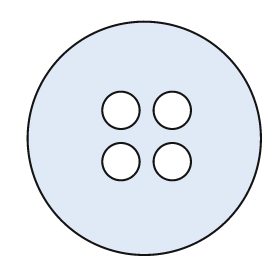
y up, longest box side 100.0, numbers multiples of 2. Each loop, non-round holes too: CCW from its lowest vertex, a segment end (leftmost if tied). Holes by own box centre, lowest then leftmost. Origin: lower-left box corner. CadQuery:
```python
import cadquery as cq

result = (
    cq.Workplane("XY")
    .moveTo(50.0, 50.0)
    .circle(50.0)
    .moveTo(40.0, 40.0)
    .circle(8.0)
    .moveTo(62.0, 40.0)
    .circle(8.0)
    .moveTo(40.0, 62.0)
    .circle(8.0)
    .moveTo(62.0, 62.0)
    .circle(8.0)
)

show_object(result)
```